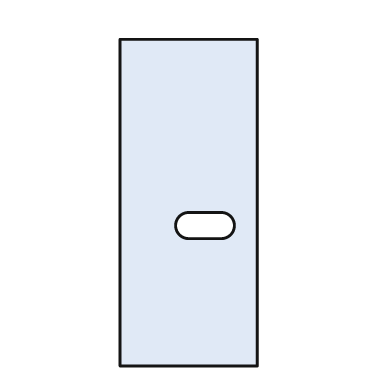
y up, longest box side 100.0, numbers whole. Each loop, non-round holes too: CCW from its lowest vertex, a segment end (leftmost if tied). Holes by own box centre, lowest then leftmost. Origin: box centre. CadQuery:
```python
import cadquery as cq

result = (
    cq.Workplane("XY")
    .moveTo(-21.0, -50.0)
    .lineTo(21.0, -50.0)
    .lineTo(21.0, 50.0)
    .lineTo(-21.0, 50.0)
    .close()
    .moveTo(0.0, -11.0)
    .lineTo(10.0, -11.0)
    .threePointArc((14.0, -7.0), (10.0, -3.0))
    .lineTo(0.0, -3.0)
    .threePointArc((-4.0, -7.0), (0.0, -11.0))
    .close()
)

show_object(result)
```